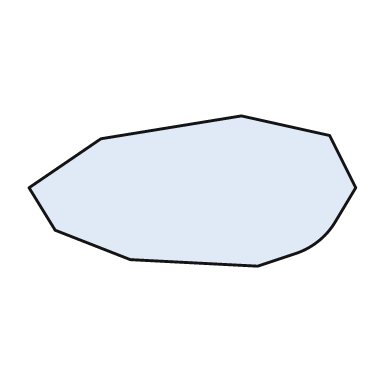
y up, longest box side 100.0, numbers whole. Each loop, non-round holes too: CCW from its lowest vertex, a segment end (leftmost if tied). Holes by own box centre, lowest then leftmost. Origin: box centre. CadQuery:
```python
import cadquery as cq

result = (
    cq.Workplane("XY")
    .moveTo(20.0, -23.0)
    .lineTo(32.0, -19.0)
    .threePointArc((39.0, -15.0), (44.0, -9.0))
    .lineTo(50.0, 1.0)
    .lineTo(42.0, 17.0)
    .lineTo(15.0, 23.0)
    .lineTo(-28.0, 16.0)
    .lineTo(-50.0, 1.0)
    .lineTo(-42.0, -12.0)
    .lineTo(-19.0, -21.0)
    .close()
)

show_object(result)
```